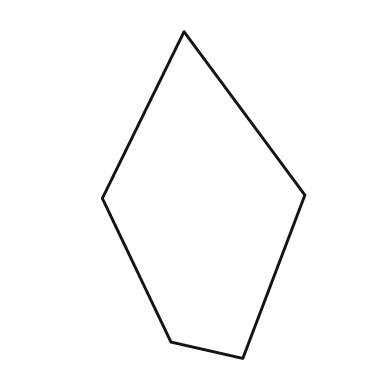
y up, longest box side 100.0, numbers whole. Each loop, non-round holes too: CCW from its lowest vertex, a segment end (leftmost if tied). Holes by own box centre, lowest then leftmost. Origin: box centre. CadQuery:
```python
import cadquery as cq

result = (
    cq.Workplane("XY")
    .moveTo(12.0, -50.0)
    .lineTo(31.0, 0.0)
    .lineTo(-6.0, 50.0)
    .lineTo(-31.0, -1.0)
    .lineTo(-10.0, -45.0)
    .close()
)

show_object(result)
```